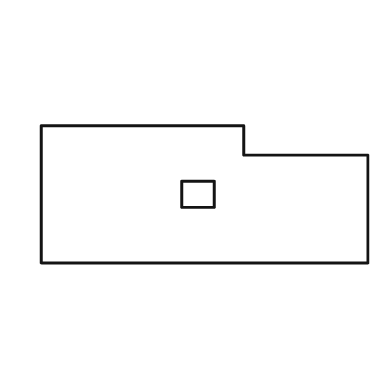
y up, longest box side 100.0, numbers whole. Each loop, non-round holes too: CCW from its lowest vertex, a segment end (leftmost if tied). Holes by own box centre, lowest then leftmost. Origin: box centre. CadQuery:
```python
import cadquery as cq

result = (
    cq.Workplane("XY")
    .moveTo(-50.0, -21.0)
    .lineTo(50.0, -21.0)
    .lineTo(50.0, 12.0)
    .lineTo(12.0, 12.0)
    .lineTo(12.0, 21.0)
    .lineTo(-50.0, 21.0)
    .close()
    .moveTo(-7.0, -4.0)
    .lineTo(3.0, -4.0)
    .lineTo(3.0, 4.0)
    .lineTo(-7.0, 4.0)
    .close()
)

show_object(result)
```